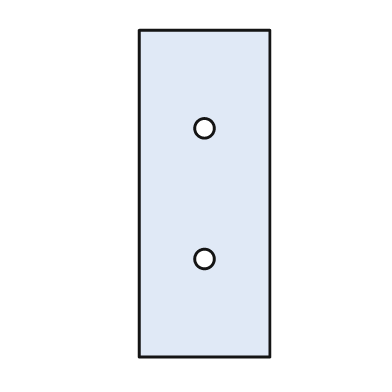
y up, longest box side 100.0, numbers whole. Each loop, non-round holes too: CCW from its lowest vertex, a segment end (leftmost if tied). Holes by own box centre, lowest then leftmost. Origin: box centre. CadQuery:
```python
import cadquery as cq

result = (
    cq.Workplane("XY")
    .moveTo(-20.0, -50.0)
    .lineTo(20.0, -50.0)
    .lineTo(20.0, 50.0)
    .lineTo(-20.0, 50.0)
    .close()
    .moveTo(0.0, -20.0)
    .circle(3.0)
    .moveTo(0.0, 20.0)
    .circle(3.0)
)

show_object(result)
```